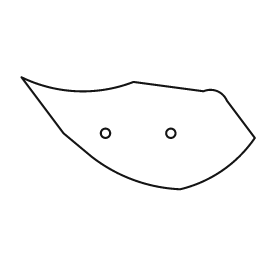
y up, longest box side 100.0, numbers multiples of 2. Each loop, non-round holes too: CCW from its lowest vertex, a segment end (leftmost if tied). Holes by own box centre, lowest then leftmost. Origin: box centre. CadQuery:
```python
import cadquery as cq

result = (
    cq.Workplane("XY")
    .moveTo(18.0, -24.0)
    .threePointArc((36.0, -16.0), (50.0, -2.0))
    .lineTo(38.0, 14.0)
    .threePointArc((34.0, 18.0), (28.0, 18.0))
    .lineTo(-2.0, 22.0)
    .threePointArc((-26.0, 18.0), (-50.0, 24.0))
    .lineTo(-32.0, 0.0)
    .lineTo(-20.0, -10.0)
    .threePointArc((-2.0, -20.0), (18.0, -24.0))
    .close()
    .moveTo(-14.0, 0.0)
    .circle(2.0)
    .moveTo(14.0, 0.0)
    .circle(2.0)
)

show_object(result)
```